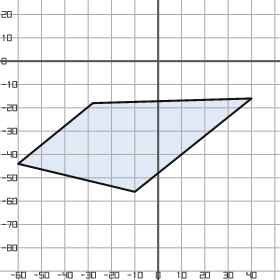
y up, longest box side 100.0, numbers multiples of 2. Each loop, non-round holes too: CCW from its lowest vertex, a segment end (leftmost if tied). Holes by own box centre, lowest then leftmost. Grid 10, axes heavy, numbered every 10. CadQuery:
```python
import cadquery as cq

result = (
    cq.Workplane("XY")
    .moveTo(-10.0, -56.0)
    .lineTo(40.0, -16.0)
    .lineTo(-28.0, -18.0)
    .lineTo(-60.0, -44.0)
    .close()
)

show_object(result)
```